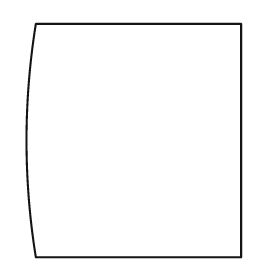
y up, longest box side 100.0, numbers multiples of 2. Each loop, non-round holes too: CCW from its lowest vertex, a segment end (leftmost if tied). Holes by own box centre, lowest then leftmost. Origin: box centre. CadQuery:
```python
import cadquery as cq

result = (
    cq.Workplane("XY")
    .moveTo(-42.0, -50.0)
    .lineTo(46.0, -50.0)
    .lineTo(46.0, 50.0)
    .lineTo(-42.0, 50.0)
    .threePointArc((-46.0, 0.0), (-42.0, -50.0))
    .close()
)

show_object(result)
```